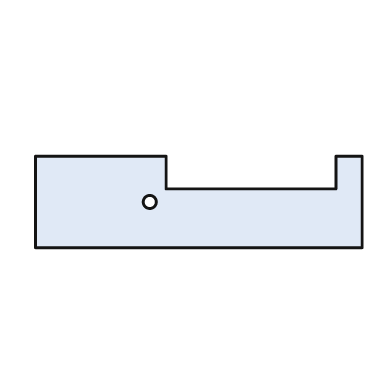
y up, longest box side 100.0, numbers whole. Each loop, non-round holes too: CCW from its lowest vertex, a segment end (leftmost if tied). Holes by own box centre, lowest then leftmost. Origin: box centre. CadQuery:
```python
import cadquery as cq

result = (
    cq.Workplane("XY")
    .moveTo(-50.0, -14.0)
    .lineTo(50.0, -14.0)
    .lineTo(50.0, 14.0)
    .lineTo(42.0, 14.0)
    .lineTo(42.0, 4.0)
    .lineTo(-10.0, 4.0)
    .lineTo(-10.0, 14.0)
    .lineTo(-50.0, 14.0)
    .close()
    .moveTo(-15.0, 0.0)
    .circle(2.0)
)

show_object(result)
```